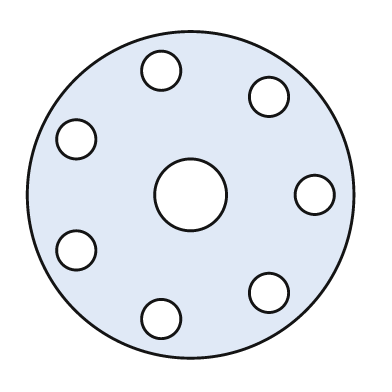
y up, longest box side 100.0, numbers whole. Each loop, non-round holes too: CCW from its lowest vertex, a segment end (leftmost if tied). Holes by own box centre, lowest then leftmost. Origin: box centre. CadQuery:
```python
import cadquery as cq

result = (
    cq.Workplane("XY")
    .moveTo(0.0, 0.0)
    .circle(50.0)
    .moveTo(-9.0, -38.0)
    .circle(6.0)
    .moveTo(24.0, -30.0)
    .circle(6.0)
    .moveTo(-35.0, -17.0)
    .circle(6.0)
    .moveTo(0.0, 0.0)
    .circle(11.0)
    .moveTo(38.0, 0.0)
    .circle(6.0)
    .moveTo(-35.0, 17.0)
    .circle(6.0)
    .moveTo(24.0, 30.0)
    .circle(6.0)
    .moveTo(-9.0, 38.0)
    .circle(6.0)
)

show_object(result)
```